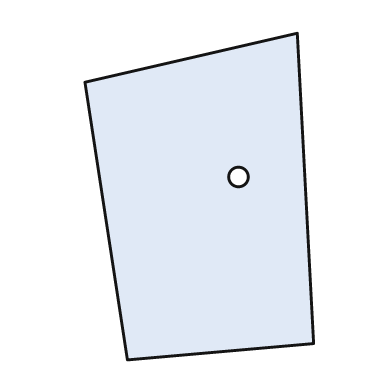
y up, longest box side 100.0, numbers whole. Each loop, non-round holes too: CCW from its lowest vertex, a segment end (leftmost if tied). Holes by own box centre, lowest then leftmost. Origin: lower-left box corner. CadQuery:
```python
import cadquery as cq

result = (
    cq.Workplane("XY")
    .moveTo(13.0, 0.0)
    .lineTo(70.0, 5.0)
    .lineTo(65.0, 100.0)
    .lineTo(0.0, 85.0)
    .close()
    .moveTo(47.0, 56.0)
    .circle(3.0)
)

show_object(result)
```